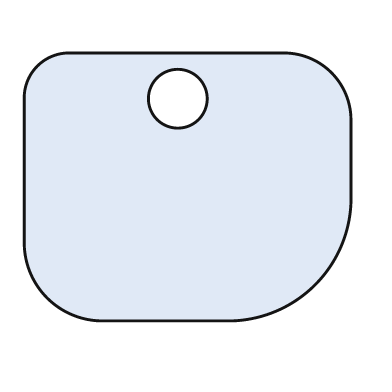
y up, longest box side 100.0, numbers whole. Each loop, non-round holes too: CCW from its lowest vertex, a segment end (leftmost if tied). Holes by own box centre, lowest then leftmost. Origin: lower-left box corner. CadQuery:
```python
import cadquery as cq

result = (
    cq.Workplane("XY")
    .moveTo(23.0, 0.0)
    .lineTo(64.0, 0.0)
    .threePointArc((89.0, 11.0), (100.0, 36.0))
    .lineTo(100.0, 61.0)
    .threePointArc((94.0, 76.0), (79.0, 82.0))
    .lineTo(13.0, 82.0)
    .threePointArc((4.0, 78.0), (0.0, 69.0))
    .lineTo(0.0, 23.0)
    .threePointArc((7.0, 7.0), (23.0, 0.0))
    .close()
    .moveTo(47.0, 68.0)
    .circle(9.0)
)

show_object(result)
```